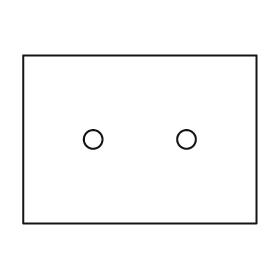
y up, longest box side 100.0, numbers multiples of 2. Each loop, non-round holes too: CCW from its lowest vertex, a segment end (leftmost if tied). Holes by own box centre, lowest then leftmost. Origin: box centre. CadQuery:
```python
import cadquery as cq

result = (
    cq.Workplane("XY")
    .moveTo(-50.0, -36.0)
    .lineTo(50.0, -36.0)
    .lineTo(50.0, 36.0)
    .lineTo(-50.0, 36.0)
    .close()
    .moveTo(-20.0, 0.0)
    .circle(4.0)
    .moveTo(20.0, 0.0)
    .circle(4.0)
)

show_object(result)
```